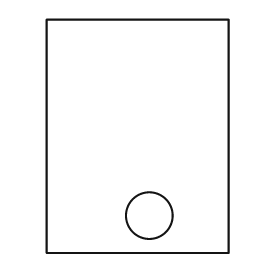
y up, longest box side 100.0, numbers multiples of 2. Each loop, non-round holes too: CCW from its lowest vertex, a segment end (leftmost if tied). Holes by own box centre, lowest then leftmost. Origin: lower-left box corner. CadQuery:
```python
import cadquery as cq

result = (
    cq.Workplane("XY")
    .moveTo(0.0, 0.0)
    .lineTo(78.0, 0.0)
    .lineTo(78.0, 100.0)
    .lineTo(0.0, 100.0)
    .close()
    .moveTo(44.0, 16.0)
    .circle(10.0)
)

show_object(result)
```